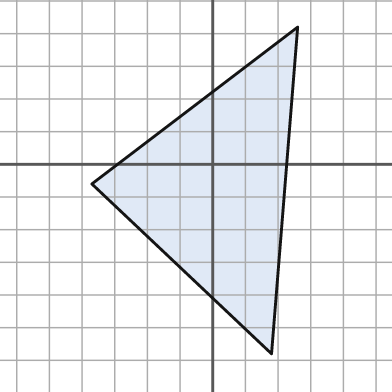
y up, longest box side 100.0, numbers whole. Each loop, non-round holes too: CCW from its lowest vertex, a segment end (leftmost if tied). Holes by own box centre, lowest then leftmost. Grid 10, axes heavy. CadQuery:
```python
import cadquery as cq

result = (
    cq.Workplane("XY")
    .moveTo(18.0, -58.0)
    .lineTo(26.0, 42.0)
    .lineTo(-37.0, -6.0)
    .close()
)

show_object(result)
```